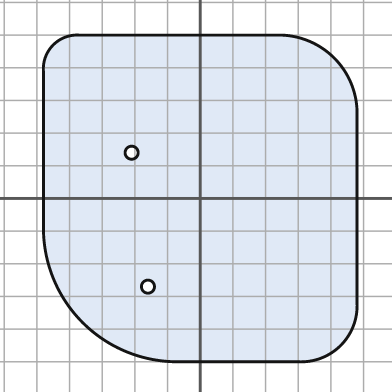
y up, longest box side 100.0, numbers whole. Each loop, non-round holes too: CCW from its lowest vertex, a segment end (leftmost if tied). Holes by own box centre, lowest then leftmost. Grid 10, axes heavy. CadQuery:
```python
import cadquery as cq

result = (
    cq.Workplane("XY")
    .moveTo(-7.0, -50.0)
    .lineTo(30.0, -50.0)
    .threePointArc((43.0, -45.0), (48.0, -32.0))
    .lineTo(48.0, 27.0)
    .threePointArc((41.0, 43.0), (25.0, 50.0))
    .lineTo(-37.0, 50.0)
    .threePointArc((-45.0, 47.0), (-48.0, 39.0))
    .lineTo(-48.0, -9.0)
    .threePointArc((-36.0, -38.0), (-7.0, -50.0))
    .close()
    .moveTo(-16.0, -27.0)
    .circle(2.0)
    .moveTo(-21.0, 14.0)
    .circle(2.0)
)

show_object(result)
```